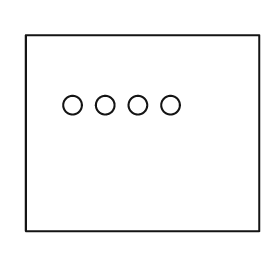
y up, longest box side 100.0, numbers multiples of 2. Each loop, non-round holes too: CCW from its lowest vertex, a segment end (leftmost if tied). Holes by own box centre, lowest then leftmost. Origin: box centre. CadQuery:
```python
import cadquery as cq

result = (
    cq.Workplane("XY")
    .moveTo(-50.0, -42.0)
    .lineTo(50.0, -42.0)
    .lineTo(50.0, 42.0)
    .lineTo(-50.0, 42.0)
    .close()
    .moveTo(-30.0, 12.0)
    .circle(4.0)
    .moveTo(-16.0, 12.0)
    .circle(4.0)
    .moveTo(-2.0, 12.0)
    .circle(4.0)
    .moveTo(12.0, 12.0)
    .circle(4.0)
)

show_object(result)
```